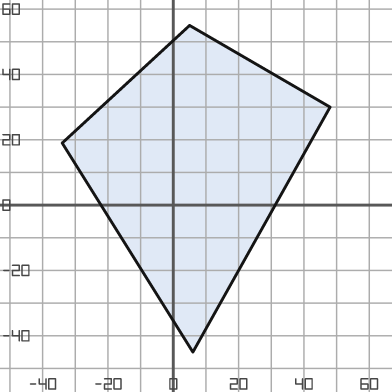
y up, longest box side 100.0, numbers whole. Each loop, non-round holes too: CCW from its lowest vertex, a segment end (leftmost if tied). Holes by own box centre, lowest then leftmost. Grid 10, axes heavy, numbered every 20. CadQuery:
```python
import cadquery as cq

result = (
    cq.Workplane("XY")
    .moveTo(6.0, -45.0)
    .lineTo(48.0, 30.0)
    .lineTo(5.0, 55.0)
    .lineTo(-34.0, 19.0)
    .close()
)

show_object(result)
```